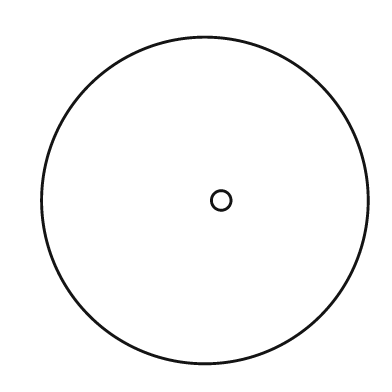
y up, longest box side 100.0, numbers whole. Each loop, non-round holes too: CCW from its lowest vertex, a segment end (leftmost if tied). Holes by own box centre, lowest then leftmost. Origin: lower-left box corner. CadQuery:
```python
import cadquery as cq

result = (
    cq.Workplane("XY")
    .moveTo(50.0, 50.0)
    .circle(50.0)
    .moveTo(55.0, 50.0)
    .circle(3.0)
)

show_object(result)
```